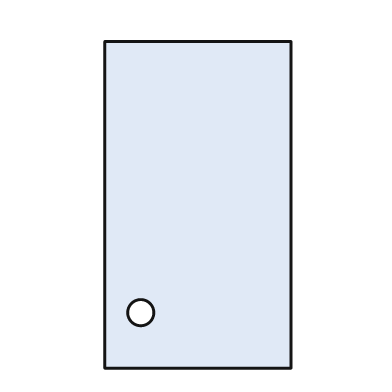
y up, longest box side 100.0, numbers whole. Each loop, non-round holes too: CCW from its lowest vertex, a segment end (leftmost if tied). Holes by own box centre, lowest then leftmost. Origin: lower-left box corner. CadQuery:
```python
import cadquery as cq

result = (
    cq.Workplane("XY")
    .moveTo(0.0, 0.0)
    .lineTo(57.0, 0.0)
    .lineTo(57.0, 100.0)
    .lineTo(0.0, 100.0)
    .close()
    .moveTo(11.0, 17.0)
    .circle(4.0)
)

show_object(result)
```